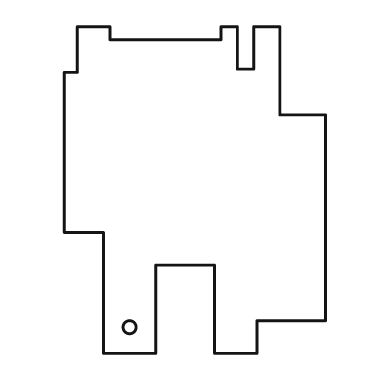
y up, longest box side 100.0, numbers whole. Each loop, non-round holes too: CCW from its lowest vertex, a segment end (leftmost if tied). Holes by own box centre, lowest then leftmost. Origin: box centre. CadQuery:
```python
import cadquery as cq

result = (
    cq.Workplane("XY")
    .moveTo(-28.0, -50.0)
    .lineTo(-12.0, -50.0)
    .lineTo(-12.0, -23.0)
    .lineTo(6.0, -23.0)
    .lineTo(6.0, -50.0)
    .lineTo(19.0, -50.0)
    .lineTo(19.0, -40.0)
    .lineTo(40.0, -40.0)
    .lineTo(40.0, 23.0)
    .lineTo(26.0, 23.0)
    .lineTo(26.0, 50.0)
    .lineTo(18.0, 50.0)
    .lineTo(18.0, 37.0)
    .lineTo(13.0, 37.0)
    .lineTo(13.0, 50.0)
    .lineTo(8.0, 50.0)
    .lineTo(8.0, 46.0)
    .lineTo(-26.0, 46.0)
    .lineTo(-26.0, 50.0)
    .lineTo(-36.0, 50.0)
    .lineTo(-36.0, 36.0)
    .lineTo(-40.0, 36.0)
    .lineTo(-40.0, -13.0)
    .lineTo(-28.0, -13.0)
    .close()
    .moveTo(-20.0, -42.0)
    .circle(2.0)
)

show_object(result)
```